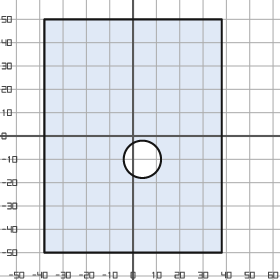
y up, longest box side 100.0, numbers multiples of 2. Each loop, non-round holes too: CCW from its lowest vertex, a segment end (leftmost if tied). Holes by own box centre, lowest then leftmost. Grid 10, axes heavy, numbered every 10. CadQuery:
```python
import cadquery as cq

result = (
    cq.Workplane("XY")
    .moveTo(-38.0, -50.0)
    .lineTo(38.0, -50.0)
    .lineTo(38.0, 50.0)
    .lineTo(-38.0, 50.0)
    .close()
    .moveTo(4.0, -10.0)
    .circle(8.0)
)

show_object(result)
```